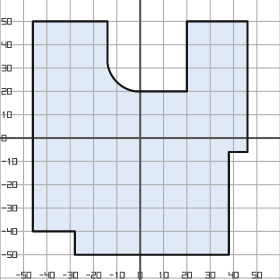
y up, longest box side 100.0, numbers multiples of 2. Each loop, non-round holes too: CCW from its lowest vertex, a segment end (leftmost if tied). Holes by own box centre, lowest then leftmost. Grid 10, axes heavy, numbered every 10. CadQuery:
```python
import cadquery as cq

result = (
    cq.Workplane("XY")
    .moveTo(-28.0, -50.0)
    .lineTo(38.0, -50.0)
    .lineTo(38.0, -6.0)
    .lineTo(46.0, -6.0)
    .lineTo(46.0, 50.0)
    .lineTo(20.0, 50.0)
    .lineTo(20.0, 20.0)
    .lineTo(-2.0, 20.0)
    .threePointArc((-10.0, 24.0), (-14.0, 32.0))
    .lineTo(-14.0, 50.0)
    .lineTo(-46.0, 50.0)
    .lineTo(-46.0, -40.0)
    .lineTo(-28.0, -40.0)
    .close()
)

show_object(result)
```